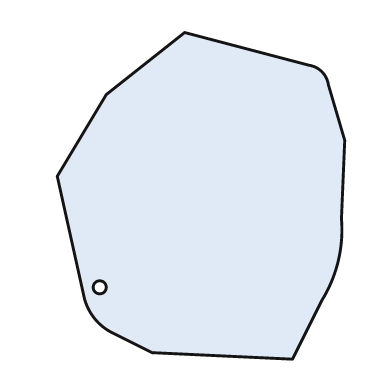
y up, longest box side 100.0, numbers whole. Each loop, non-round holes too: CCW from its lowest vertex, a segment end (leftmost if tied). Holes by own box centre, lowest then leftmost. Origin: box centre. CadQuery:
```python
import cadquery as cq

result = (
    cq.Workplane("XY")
    .moveTo(28.0, -50.0)
    .lineTo(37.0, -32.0)
    .threePointArc((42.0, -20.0), (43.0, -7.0))
    .lineTo(44.0, 17.0)
    .lineTo(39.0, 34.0)
    .threePointArc((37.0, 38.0), (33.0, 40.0))
    .lineTo(-5.0, 50.0)
    .lineTo(-29.0, 31.0)
    .lineTo(-44.0, 6.0)
    .lineTo(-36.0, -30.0)
    .threePointArc((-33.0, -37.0), (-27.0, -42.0))
    .lineTo(-15.0, -48.0)
    .close()
    .moveTo(-31.0, -28.0)
    .circle(2.0)
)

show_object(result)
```